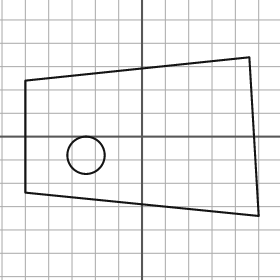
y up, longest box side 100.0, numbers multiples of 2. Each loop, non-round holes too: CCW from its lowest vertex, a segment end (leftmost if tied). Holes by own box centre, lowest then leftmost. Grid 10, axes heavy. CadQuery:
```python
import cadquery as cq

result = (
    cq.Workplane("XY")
    .moveTo(50.0, -34.0)
    .lineTo(46.0, 34.0)
    .lineTo(-50.0, 24.0)
    .lineTo(-50.0, -24.0)
    .close()
    .moveTo(-24.0, -8.0)
    .circle(8.0)
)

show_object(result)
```